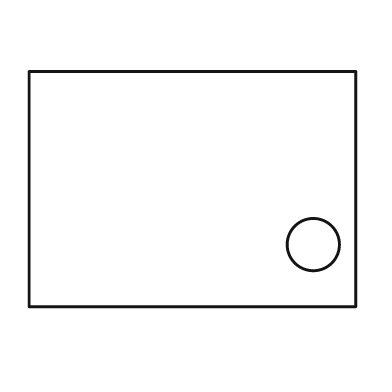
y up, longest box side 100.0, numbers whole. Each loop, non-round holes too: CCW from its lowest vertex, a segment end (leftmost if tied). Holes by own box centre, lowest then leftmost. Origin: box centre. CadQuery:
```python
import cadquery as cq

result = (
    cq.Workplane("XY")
    .moveTo(-50.0, -36.0)
    .lineTo(50.0, -36.0)
    .lineTo(50.0, 36.0)
    .lineTo(-50.0, 36.0)
    .close()
    .moveTo(37.0, -17.0)
    .circle(8.0)
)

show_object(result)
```